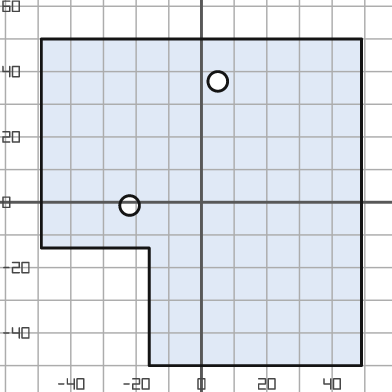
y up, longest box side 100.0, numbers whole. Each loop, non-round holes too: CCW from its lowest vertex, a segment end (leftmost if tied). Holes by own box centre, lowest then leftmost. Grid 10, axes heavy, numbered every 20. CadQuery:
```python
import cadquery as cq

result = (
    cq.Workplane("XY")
    .moveTo(-16.0, -50.0)
    .lineTo(49.0, -50.0)
    .lineTo(49.0, 50.0)
    .lineTo(-49.0, 50.0)
    .lineTo(-49.0, -14.0)
    .lineTo(-16.0, -14.0)
    .close()
    .moveTo(-22.0, -1.0)
    .circle(3.0)
    .moveTo(5.0, 37.0)
    .circle(3.0)
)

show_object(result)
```